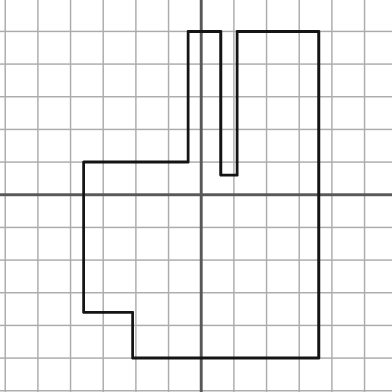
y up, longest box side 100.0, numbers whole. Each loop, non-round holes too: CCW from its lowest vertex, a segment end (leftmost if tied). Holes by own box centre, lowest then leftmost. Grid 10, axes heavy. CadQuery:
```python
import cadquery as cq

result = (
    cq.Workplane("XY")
    .moveTo(-21.0, -50.0)
    .lineTo(36.0, -50.0)
    .lineTo(36.0, 50.0)
    .lineTo(11.0, 50.0)
    .lineTo(11.0, 6.0)
    .lineTo(6.0, 6.0)
    .lineTo(6.0, 50.0)
    .lineTo(-4.0, 50.0)
    .lineTo(-4.0, 10.0)
    .lineTo(-36.0, 10.0)
    .lineTo(-36.0, -36.0)
    .lineTo(-21.0, -36.0)
    .close()
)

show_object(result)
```